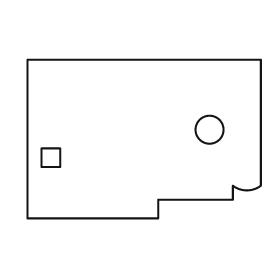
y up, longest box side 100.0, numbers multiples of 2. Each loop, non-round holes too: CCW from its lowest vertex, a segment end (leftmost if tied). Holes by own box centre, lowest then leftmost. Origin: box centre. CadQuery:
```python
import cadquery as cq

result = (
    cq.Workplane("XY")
    .moveTo(-50.0, -34.0)
    .lineTo(6.0, -34.0)
    .lineTo(6.0, -26.0)
    .lineTo(38.0, -26.0)
    .lineTo(38.0, -20.0)
    .threePointArc((44.0, -22.0), (50.0, -20.0))
    .lineTo(50.0, 34.0)
    .lineTo(-50.0, 34.0)
    .close()
    .moveTo(-44.0, -12.0)
    .lineTo(-36.0, -12.0)
    .lineTo(-36.0, -4.0)
    .lineTo(-44.0, -4.0)
    .close()
    .moveTo(28.0, 4.0)
    .circle(6.0)
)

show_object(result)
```